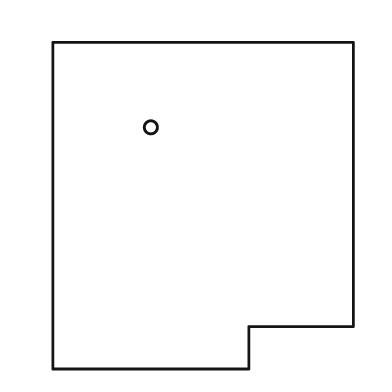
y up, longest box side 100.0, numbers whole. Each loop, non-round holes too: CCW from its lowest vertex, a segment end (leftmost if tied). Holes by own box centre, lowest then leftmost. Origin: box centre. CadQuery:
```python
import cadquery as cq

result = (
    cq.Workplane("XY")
    .moveTo(-46.0, -50.0)
    .lineTo(14.0, -50.0)
    .lineTo(14.0, -37.0)
    .lineTo(46.0, -37.0)
    .lineTo(46.0, 50.0)
    .lineTo(-46.0, 50.0)
    .close()
    .moveTo(-16.0, 24.0)
    .circle(2.0)
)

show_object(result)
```